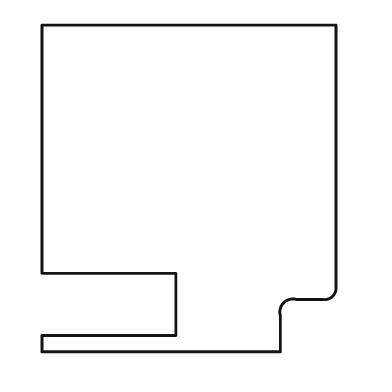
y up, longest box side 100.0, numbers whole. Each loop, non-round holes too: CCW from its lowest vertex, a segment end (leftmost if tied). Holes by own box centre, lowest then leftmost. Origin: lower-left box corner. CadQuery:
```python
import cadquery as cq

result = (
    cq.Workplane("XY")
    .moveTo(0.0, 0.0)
    .lineTo(73.0, 0.0)
    .lineTo(73.0, 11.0)
    .threePointArc((74.0, 15.0), (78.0, 16.0))
    .lineTo(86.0, 16.0)
    .threePointArc((89.0, 17.0), (90.0, 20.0))
    .lineTo(90.0, 100.0)
    .lineTo(0.0, 100.0)
    .lineTo(0.0, 24.0)
    .lineTo(41.0, 24.0)
    .lineTo(41.0, 5.0)
    .lineTo(0.0, 5.0)
    .close()
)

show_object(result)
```